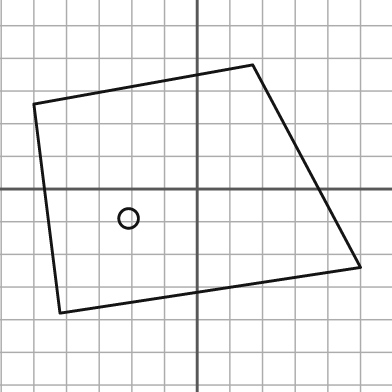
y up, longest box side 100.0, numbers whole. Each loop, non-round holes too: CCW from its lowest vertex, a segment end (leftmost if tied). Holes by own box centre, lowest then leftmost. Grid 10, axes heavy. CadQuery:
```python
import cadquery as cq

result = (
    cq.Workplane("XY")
    .moveTo(-42.0, -38.0)
    .lineTo(50.0, -24.0)
    .lineTo(17.0, 38.0)
    .lineTo(-50.0, 26.0)
    .close()
    .moveTo(-21.0, -9.0)
    .circle(3.0)
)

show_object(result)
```